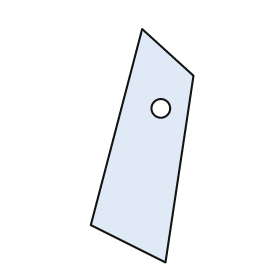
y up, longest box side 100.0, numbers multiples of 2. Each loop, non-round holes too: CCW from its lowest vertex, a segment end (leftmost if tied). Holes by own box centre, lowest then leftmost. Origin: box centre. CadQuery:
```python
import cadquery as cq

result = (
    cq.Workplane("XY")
    .moveTo(10.0, -50.0)
    .lineTo(22.0, 30.0)
    .lineTo(0.0, 50.0)
    .lineTo(-22.0, -34.0)
    .close()
    .moveTo(8.0, 16.0)
    .circle(4.0)
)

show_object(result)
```